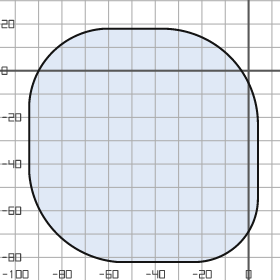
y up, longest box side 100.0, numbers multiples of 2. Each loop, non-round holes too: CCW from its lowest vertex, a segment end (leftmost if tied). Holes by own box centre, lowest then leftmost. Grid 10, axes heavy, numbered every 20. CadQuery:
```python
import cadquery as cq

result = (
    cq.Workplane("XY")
    .moveTo(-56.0, -82.0)
    .lineTo(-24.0, -82.0)
    .threePointArc((-4.0, -74.0), (4.0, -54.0))
    .lineTo(4.0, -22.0)
    .threePointArc((-8.0, 6.0), (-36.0, 18.0))
    .lineTo(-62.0, 18.0)
    .threePointArc((-84.0, 8.0), (-94.0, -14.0))
    .lineTo(-94.0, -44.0)
    .threePointArc((-82.0, -70.0), (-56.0, -82.0))
    .close()
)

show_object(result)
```